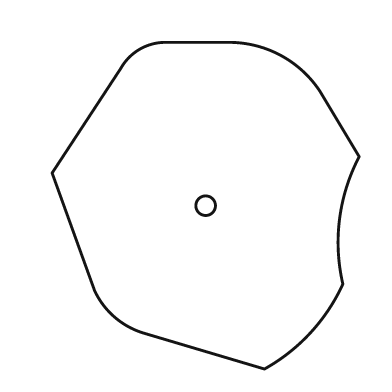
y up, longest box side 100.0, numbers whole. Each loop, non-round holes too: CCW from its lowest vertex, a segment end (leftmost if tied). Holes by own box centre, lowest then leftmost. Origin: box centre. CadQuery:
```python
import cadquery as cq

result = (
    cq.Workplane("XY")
    .moveTo(18.0, -50.0)
    .threePointArc((32.0, -39.0), (42.0, -24.0))
    .threePointArc((41.0, -4.0), (47.0, 15.0))
    .lineTo(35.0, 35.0)
    .threePointArc((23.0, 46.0), (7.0, 50.0))
    .lineTo(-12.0, 50.0)
    .threePointArc((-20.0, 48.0), (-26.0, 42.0))
    .lineTo(-47.0, 10.0)
    .lineTo(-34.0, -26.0)
    .threePointArc((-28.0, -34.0), (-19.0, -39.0))
    .close()
    .moveTo(0.0, 0.0)
    .circle(3.0)
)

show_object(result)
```